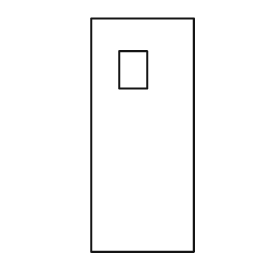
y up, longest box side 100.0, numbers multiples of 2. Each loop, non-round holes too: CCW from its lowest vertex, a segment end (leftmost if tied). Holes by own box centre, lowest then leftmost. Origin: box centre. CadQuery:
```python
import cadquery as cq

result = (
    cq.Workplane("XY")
    .moveTo(-22.0, -50.0)
    .lineTo(22.0, -50.0)
    .lineTo(22.0, 50.0)
    .lineTo(-22.0, 50.0)
    .close()
    .moveTo(-10.0, 20.0)
    .lineTo(2.0, 20.0)
    .lineTo(2.0, 36.0)
    .lineTo(-10.0, 36.0)
    .close()
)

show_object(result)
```